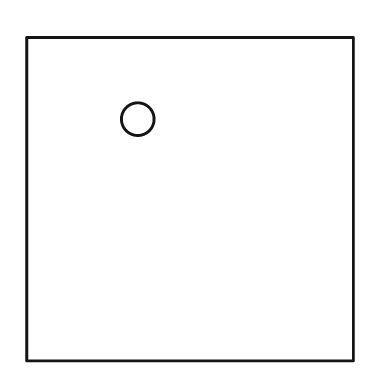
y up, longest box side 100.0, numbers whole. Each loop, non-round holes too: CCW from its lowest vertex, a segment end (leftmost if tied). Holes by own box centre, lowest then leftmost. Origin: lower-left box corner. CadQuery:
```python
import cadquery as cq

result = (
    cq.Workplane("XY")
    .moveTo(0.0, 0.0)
    .lineTo(100.0, 0.0)
    .lineTo(100.0, 99.0)
    .lineTo(0.0, 99.0)
    .close()
    .moveTo(34.0, 74.0)
    .circle(5.0)
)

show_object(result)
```